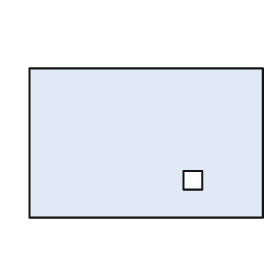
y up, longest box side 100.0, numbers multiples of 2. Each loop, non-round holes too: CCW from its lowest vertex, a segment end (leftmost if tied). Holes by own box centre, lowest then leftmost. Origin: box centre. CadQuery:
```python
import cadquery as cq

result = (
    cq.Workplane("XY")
    .moveTo(-50.0, -32.0)
    .lineTo(50.0, -32.0)
    .lineTo(50.0, 32.0)
    .lineTo(-50.0, 32.0)
    .close()
    .moveTo(16.0, -20.0)
    .lineTo(24.0, -20.0)
    .lineTo(24.0, -12.0)
    .lineTo(16.0, -12.0)
    .close()
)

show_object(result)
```